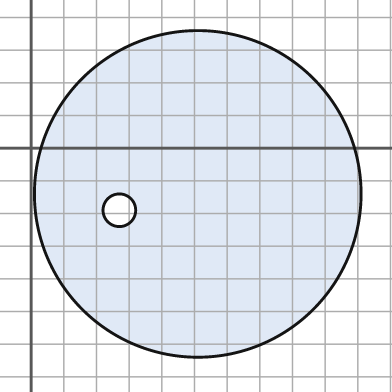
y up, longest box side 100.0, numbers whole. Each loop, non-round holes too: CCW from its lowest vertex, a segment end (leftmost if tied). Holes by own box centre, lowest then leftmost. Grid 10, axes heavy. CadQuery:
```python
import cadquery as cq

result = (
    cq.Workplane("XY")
    .moveTo(51.0, -14.0)
    .circle(50.0)
    .moveTo(27.0, -19.0)
    .circle(5.0)
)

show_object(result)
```